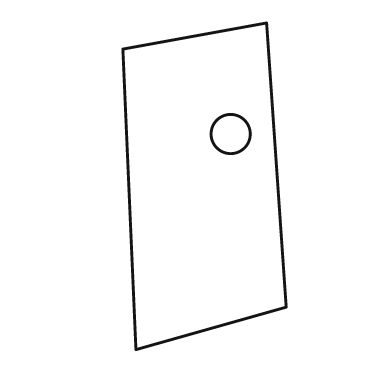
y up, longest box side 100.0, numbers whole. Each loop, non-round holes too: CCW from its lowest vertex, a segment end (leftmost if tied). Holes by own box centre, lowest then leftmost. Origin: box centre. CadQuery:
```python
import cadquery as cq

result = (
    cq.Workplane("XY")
    .moveTo(-21.0, -50.0)
    .lineTo(25.0, -37.0)
    .lineTo(19.0, 50.0)
    .lineTo(-25.0, 42.0)
    .close()
    .moveTo(8.0, 16.0)
    .circle(6.0)
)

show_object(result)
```